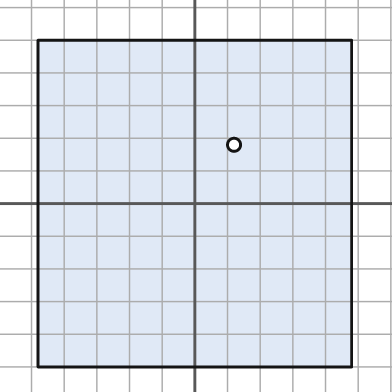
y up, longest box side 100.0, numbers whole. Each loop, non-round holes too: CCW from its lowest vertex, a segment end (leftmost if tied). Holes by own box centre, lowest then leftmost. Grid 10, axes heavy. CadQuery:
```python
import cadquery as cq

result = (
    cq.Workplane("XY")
    .moveTo(-48.0, -50.0)
    .lineTo(48.0, -50.0)
    .lineTo(48.0, 50.0)
    .lineTo(-48.0, 50.0)
    .close()
    .moveTo(12.0, 18.0)
    .circle(2.0)
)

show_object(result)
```